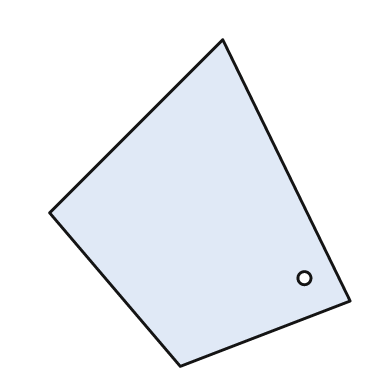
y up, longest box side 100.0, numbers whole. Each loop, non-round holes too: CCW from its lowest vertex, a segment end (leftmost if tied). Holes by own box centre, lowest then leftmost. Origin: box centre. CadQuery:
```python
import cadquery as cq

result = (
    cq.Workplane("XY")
    .moveTo(-6.0, -50.0)
    .lineTo(46.0, -30.0)
    .lineTo(7.0, 50.0)
    .lineTo(-46.0, -3.0)
    .close()
    .moveTo(32.0, -23.0)
    .circle(2.0)
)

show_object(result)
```